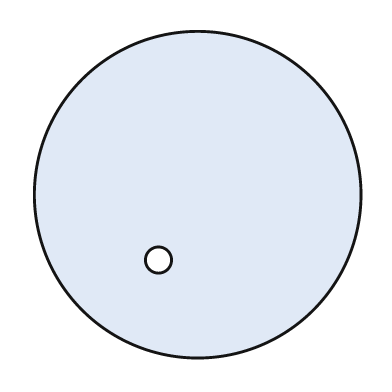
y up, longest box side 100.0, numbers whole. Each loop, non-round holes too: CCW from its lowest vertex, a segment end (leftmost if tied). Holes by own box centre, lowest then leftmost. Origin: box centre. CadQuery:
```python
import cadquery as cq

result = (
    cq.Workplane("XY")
    .moveTo(0.0, 0.0)
    .circle(50.0)
    .moveTo(-12.0, -20.0)
    .circle(4.0)
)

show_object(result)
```